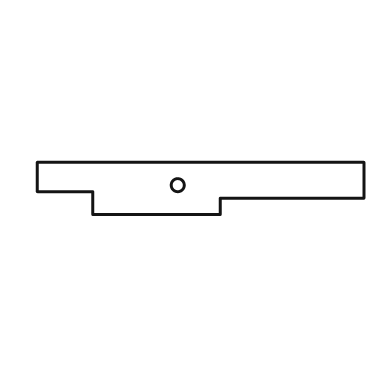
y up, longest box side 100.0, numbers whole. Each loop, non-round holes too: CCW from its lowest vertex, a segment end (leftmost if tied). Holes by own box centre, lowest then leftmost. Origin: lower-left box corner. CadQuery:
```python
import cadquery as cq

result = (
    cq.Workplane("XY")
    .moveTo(17.0, 0.0)
    .lineTo(56.0, 0.0)
    .lineTo(56.0, 5.0)
    .lineTo(100.0, 5.0)
    .lineTo(100.0, 16.0)
    .lineTo(0.0, 16.0)
    .lineTo(0.0, 7.0)
    .lineTo(17.0, 7.0)
    .close()
    .moveTo(43.0, 9.0)
    .circle(2.0)
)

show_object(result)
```